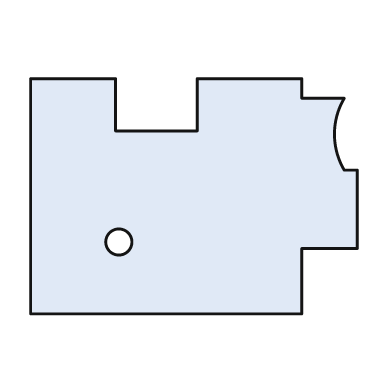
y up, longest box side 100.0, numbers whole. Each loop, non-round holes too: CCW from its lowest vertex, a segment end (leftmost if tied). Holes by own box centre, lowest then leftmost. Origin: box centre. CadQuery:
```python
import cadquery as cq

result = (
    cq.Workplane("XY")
    .moveTo(-50.0, -36.0)
    .lineTo(33.0, -36.0)
    .lineTo(33.0, -16.0)
    .lineTo(50.0, -16.0)
    .lineTo(50.0, 8.0)
    .lineTo(46.0, 8.0)
    .threePointArc((43.0, 19.0), (46.0, 30.0))
    .lineTo(33.0, 30.0)
    .lineTo(33.0, 36.0)
    .lineTo(1.0, 36.0)
    .lineTo(1.0, 20.0)
    .lineTo(-24.0, 20.0)
    .lineTo(-24.0, 36.0)
    .lineTo(-50.0, 36.0)
    .close()
    .moveTo(-23.0, -14.0)
    .circle(4.0)
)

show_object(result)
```